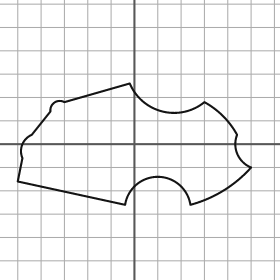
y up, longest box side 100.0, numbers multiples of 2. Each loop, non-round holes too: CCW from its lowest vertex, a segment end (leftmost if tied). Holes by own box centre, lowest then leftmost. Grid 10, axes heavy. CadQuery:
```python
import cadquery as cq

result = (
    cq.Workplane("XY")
    .moveTo(-4.0, -26.0)
    .threePointArc((10.0, -14.0), (24.0, -26.0))
    .threePointArc((38.0, -20.0), (50.0, -10.0))
    .threePointArc((44.0, -4.0), (44.0, 4.0))
    .threePointArc((38.0, 12.0), (30.0, 18.0))
    .threePointArc((12.0, 14.0), (-2.0, 26.0))
    .lineTo(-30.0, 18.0)
    .threePointArc((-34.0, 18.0), (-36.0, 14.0))
    .lineTo(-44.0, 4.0)
    .threePointArc((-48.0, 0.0), (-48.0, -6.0))
    .lineTo(-50.0, -16.0)
    .close()
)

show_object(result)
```